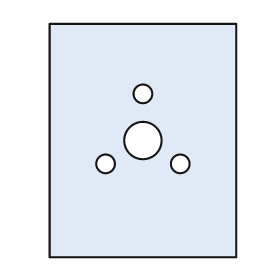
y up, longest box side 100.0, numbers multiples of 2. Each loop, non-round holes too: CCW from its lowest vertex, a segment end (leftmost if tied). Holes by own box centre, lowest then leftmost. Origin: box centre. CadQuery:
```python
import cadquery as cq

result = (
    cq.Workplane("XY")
    .moveTo(-40.0, -50.0)
    .lineTo(40.0, -50.0)
    .lineTo(40.0, 50.0)
    .lineTo(-40.0, 50.0)
    .close()
    .moveTo(-16.0, -10.0)
    .circle(4.0)
    .moveTo(16.0, -10.0)
    .circle(4.0)
    .moveTo(0.0, 0.0)
    .circle(8.0)
    .moveTo(0.0, 20.0)
    .circle(4.0)
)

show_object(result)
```